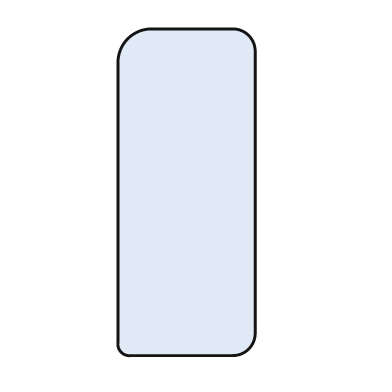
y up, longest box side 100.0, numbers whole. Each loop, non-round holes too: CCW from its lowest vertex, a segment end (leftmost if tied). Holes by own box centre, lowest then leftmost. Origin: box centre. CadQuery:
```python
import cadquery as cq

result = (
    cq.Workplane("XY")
    .moveTo(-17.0, -50.0)
    .lineTo(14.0, -50.0)
    .threePointArc((19.0, -48.0), (21.0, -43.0))
    .lineTo(21.0, 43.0)
    .threePointArc((19.0, 48.0), (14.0, 50.0))
    .lineTo(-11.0, 50.0)
    .threePointArc((-18.0, 47.0), (-21.0, 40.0))
    .lineTo(-21.0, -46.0)
    .threePointArc((-20.0, -49.0), (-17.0, -50.0))
    .close()
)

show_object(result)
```